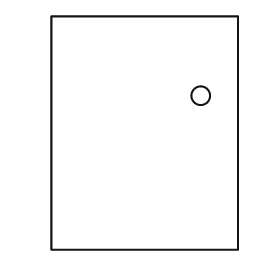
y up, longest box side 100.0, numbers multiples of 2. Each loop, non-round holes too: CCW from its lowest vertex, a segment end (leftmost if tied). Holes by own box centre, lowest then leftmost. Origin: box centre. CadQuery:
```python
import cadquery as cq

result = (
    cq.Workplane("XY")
    .moveTo(-40.0, -50.0)
    .lineTo(40.0, -50.0)
    .lineTo(40.0, 50.0)
    .lineTo(-40.0, 50.0)
    .close()
    .moveTo(24.0, 16.0)
    .circle(4.0)
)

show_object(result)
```